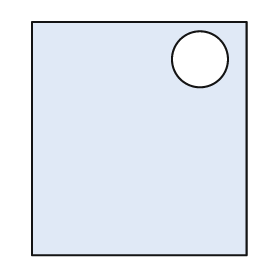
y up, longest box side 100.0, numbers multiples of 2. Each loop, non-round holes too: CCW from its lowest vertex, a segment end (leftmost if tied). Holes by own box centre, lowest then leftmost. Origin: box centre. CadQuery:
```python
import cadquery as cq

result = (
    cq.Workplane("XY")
    .moveTo(-46.0, -50.0)
    .lineTo(46.0, -50.0)
    .lineTo(46.0, 50.0)
    .lineTo(-46.0, 50.0)
    .close()
    .moveTo(26.0, 34.0)
    .circle(12.0)
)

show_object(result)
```